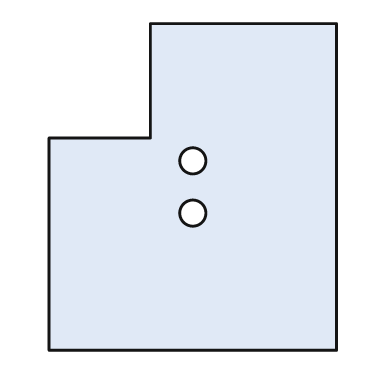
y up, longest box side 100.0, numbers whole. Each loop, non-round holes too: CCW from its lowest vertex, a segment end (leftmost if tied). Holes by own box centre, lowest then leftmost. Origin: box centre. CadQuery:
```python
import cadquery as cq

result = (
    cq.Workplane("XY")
    .moveTo(-44.0, -50.0)
    .lineTo(44.0, -50.0)
    .lineTo(44.0, 50.0)
    .lineTo(-13.0, 50.0)
    .lineTo(-13.0, 15.0)
    .lineTo(-44.0, 15.0)
    .close()
    .moveTo(0.0, -8.0)
    .circle(4.0)
    .moveTo(0.0, 8.0)
    .circle(4.0)
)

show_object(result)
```